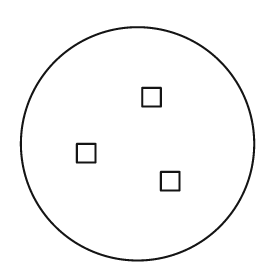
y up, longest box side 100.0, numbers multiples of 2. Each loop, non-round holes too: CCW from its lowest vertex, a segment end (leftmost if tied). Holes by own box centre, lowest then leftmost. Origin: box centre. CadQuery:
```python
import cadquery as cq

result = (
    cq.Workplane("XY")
    .moveTo(0.0, 0.0)
    .circle(50.0)
    .moveTo(10.0, -20.0)
    .lineTo(18.0, -20.0)
    .lineTo(18.0, -12.0)
    .lineTo(10.0, -12.0)
    .close()
    .moveTo(-26.0, -8.0)
    .lineTo(-18.0, -8.0)
    .lineTo(-18.0, 0.0)
    .lineTo(-26.0, 0.0)
    .close()
    .moveTo(2.0, 16.0)
    .lineTo(10.0, 16.0)
    .lineTo(10.0, 24.0)
    .lineTo(2.0, 24.0)
    .close()
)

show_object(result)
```